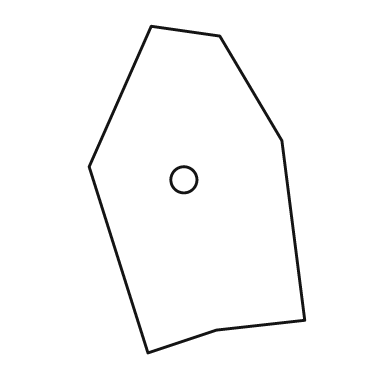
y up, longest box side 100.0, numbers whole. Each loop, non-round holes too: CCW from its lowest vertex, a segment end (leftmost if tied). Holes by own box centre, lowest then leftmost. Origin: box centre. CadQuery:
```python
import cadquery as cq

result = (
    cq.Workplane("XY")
    .moveTo(-15.0, -50.0)
    .lineTo(6.0, -43.0)
    .lineTo(33.0, -40.0)
    .lineTo(26.0, 15.0)
    .lineTo(7.0, 47.0)
    .lineTo(-14.0, 50.0)
    .lineTo(-33.0, 7.0)
    .close()
    .moveTo(-4.0, 3.0)
    .circle(4.0)
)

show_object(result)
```